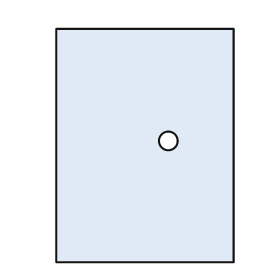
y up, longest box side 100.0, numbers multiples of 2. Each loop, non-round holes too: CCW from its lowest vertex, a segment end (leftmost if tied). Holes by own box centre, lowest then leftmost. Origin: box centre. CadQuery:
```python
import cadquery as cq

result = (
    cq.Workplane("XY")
    .moveTo(-38.0, -50.0)
    .lineTo(38.0, -50.0)
    .lineTo(38.0, 50.0)
    .lineTo(-38.0, 50.0)
    .close()
    .moveTo(10.0, 2.0)
    .circle(4.0)
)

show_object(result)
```